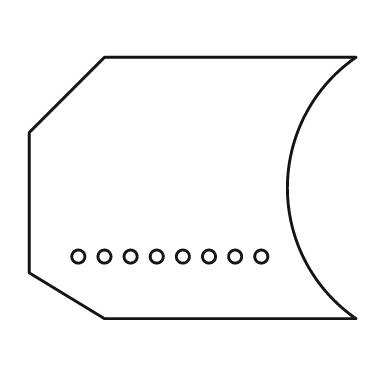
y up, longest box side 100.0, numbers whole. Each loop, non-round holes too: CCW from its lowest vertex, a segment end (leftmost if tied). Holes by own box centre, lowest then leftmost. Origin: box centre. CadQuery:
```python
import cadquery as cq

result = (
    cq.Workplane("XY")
    .moveTo(-27.0, -40.0)
    .lineTo(50.0, -40.0)
    .threePointArc((29.0, 0.0), (50.0, 40.0))
    .lineTo(-27.0, 40.0)
    .lineTo(-50.0, 17.0)
    .lineTo(-50.0, -26.0)
    .close()
    .moveTo(-35.0, -21.0)
    .circle(2.0)
    .moveTo(-27.0, -21.0)
    .circle(2.0)
    .moveTo(-19.0, -21.0)
    .circle(2.0)
    .moveTo(-11.0, -21.0)
    .circle(2.0)
    .moveTo(-3.0, -21.0)
    .circle(2.0)
    .moveTo(5.0, -21.0)
    .circle(2.0)
    .moveTo(13.0, -21.0)
    .circle(2.0)
    .moveTo(21.0, -21.0)
    .circle(2.0)
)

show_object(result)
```